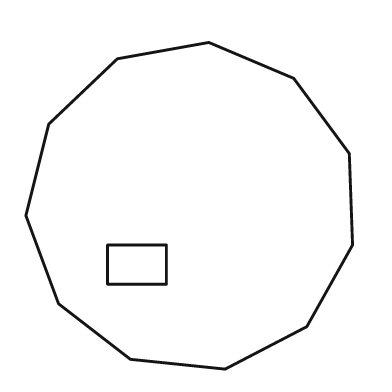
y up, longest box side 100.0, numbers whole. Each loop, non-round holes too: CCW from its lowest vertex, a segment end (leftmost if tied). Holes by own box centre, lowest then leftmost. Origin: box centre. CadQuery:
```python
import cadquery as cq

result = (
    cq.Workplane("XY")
    .moveTo(11.0, -50.0)
    .lineTo(36.0, -37.0)
    .lineTo(50.0, -12.0)
    .lineTo(49.0, 16.0)
    .lineTo(32.0, 39.0)
    .lineTo(6.0, 50.0)
    .lineTo(-22.0, 45.0)
    .lineTo(-43.0, 25.0)
    .lineTo(-50.0, -3.0)
    .lineTo(-40.0, -30.0)
    .lineTo(-18.0, -47.0)
    .close()
    .moveTo(-25.0, -24.0)
    .lineTo(-7.0, -24.0)
    .lineTo(-7.0, -12.0)
    .lineTo(-25.0, -12.0)
    .close()
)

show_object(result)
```